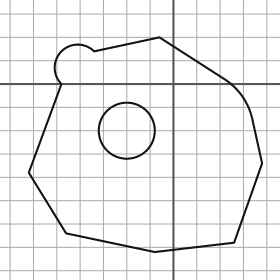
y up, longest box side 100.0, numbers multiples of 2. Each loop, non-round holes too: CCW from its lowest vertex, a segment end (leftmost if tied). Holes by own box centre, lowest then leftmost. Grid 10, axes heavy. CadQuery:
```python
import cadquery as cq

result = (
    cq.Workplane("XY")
    .moveTo(-8.0, -72.0)
    .lineTo(26.0, -68.0)
    .lineTo(38.0, -34.0)
    .lineTo(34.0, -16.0)
    .threePointArc((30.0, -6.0), (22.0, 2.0))
    .lineTo(-6.0, 20.0)
    .lineTo(-34.0, 14.0)
    .threePointArc((-48.0, 14.0), (-48.0, 0.0))
    .lineTo(-62.0, -38.0)
    .lineTo(-46.0, -64.0)
    .close()
    .moveTo(-20.0, -20.0)
    .circle(12.0)
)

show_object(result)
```